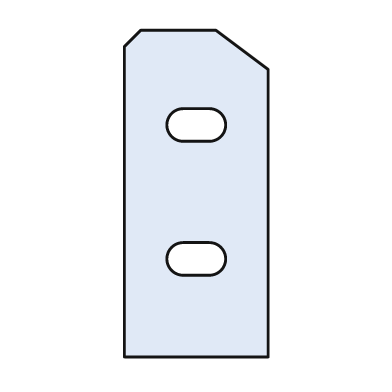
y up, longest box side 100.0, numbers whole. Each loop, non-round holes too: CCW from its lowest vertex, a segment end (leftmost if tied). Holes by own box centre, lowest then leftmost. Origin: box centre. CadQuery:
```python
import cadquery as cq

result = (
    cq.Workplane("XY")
    .moveTo(-22.0, -50.0)
    .lineTo(22.0, -50.0)
    .lineTo(22.0, 38.0)
    .lineTo(6.0, 50.0)
    .lineTo(-17.0, 50.0)
    .lineTo(-22.0, 45.0)
    .close()
    .moveTo(-4.0, -25.0)
    .lineTo(4.0, -25.0)
    .threePointArc((9.0, -20.0), (4.0, -15.0))
    .lineTo(-4.0, -15.0)
    .threePointArc((-9.0, -20.0), (-4.0, -25.0))
    .close()
    .moveTo(-4.0, 16.0)
    .lineTo(4.0, 16.0)
    .threePointArc((9.0, 21.0), (4.0, 26.0))
    .lineTo(-4.0, 26.0)
    .threePointArc((-9.0, 21.0), (-4.0, 16.0))
    .close()
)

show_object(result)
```